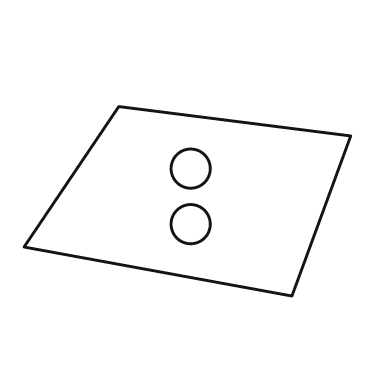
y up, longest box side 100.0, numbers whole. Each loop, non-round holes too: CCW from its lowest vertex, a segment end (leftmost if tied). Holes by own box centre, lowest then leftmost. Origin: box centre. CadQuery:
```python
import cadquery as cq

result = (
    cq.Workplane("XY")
    .moveTo(32.0, -29.0)
    .lineTo(50.0, 20.0)
    .lineTo(-21.0, 29.0)
    .lineTo(-50.0, -14.0)
    .close()
    .moveTo(1.0, -7.0)
    .circle(6.0)
    .moveTo(1.0, 10.0)
    .circle(6.0)
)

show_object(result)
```